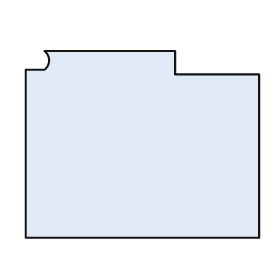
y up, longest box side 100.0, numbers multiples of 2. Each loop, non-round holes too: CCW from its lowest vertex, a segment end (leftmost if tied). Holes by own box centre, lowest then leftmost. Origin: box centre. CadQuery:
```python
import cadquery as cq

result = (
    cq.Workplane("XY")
    .moveTo(-50.0, -40.0)
    .lineTo(50.0, -40.0)
    .lineTo(50.0, 30.0)
    .lineTo(14.0, 30.0)
    .lineTo(14.0, 40.0)
    .lineTo(-42.0, 40.0)
    .threePointArc((-40.0, 36.0), (-42.0, 32.0))
    .lineTo(-50.0, 32.0)
    .close()
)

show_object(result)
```